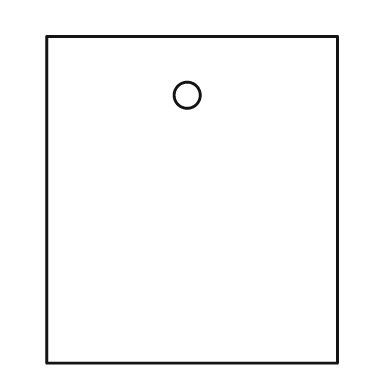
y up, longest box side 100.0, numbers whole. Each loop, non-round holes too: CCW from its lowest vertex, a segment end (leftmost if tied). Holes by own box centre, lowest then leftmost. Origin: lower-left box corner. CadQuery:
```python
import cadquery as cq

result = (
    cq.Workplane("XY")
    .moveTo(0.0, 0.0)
    .lineTo(89.0, 0.0)
    .lineTo(89.0, 100.0)
    .lineTo(0.0, 100.0)
    .close()
    .moveTo(43.0, 82.0)
    .circle(4.0)
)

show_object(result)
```